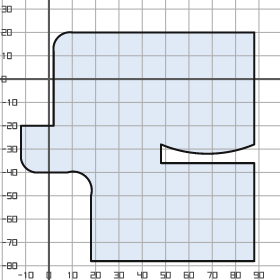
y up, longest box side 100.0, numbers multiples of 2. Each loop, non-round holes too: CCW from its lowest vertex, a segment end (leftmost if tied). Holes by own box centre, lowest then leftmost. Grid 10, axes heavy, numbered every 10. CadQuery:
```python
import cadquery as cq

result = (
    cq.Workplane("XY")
    .moveTo(18.0, -78.0)
    .lineTo(88.0, -78.0)
    .lineTo(88.0, -36.0)
    .lineTo(48.0, -36.0)
    .lineTo(48.0, -28.0)
    .threePointArc((68.0, -32.0), (88.0, -28.0))
    .lineTo(88.0, 20.0)
    .lineTo(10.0, 20.0)
    .threePointArc((4.0, 18.0), (2.0, 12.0))
    .lineTo(2.0, -20.0)
    .lineTo(-12.0, -20.0)
    .lineTo(-12.0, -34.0)
    .threePointArc((-10.0, -38.0), (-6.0, -40.0))
    .lineTo(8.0, -40.0)
    .threePointArc((16.0, -42.0), (18.0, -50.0))
    .close()
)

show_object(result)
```